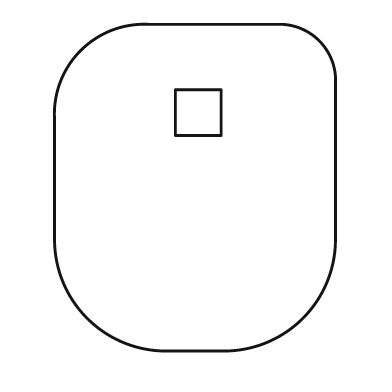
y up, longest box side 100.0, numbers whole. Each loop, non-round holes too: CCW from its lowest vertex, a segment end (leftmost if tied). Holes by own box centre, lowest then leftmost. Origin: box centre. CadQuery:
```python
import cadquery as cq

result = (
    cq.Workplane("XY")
    .moveTo(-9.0, -50.0)
    .lineTo(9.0, -50.0)
    .threePointArc((33.0, -40.0), (43.0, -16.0))
    .lineTo(43.0, 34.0)
    .threePointArc((38.0, 45.0), (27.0, 50.0))
    .lineTo(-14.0, 50.0)
    .threePointArc((-35.0, 42.0), (-43.0, 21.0))
    .lineTo(-43.0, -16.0)
    .threePointArc((-33.0, -40.0), (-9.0, -50.0))
    .close()
    .moveTo(-6.0, 16.0)
    .lineTo(8.0, 16.0)
    .lineTo(8.0, 30.0)
    .lineTo(-6.0, 30.0)
    .close()
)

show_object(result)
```